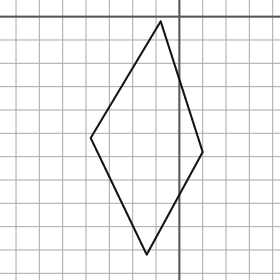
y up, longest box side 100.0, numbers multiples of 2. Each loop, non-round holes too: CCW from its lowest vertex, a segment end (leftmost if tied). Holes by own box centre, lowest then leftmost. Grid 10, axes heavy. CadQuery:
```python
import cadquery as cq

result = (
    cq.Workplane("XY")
    .moveTo(-14.0, -102.0)
    .lineTo(10.0, -58.0)
    .lineTo(-8.0, -2.0)
    .lineTo(-38.0, -52.0)
    .close()
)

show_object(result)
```